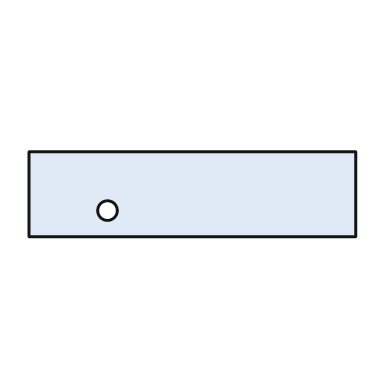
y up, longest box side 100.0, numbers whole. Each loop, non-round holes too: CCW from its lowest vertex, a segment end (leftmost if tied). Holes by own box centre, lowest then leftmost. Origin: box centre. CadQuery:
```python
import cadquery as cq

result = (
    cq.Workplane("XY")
    .moveTo(-50.0, -13.0)
    .lineTo(50.0, -13.0)
    .lineTo(50.0, 13.0)
    .lineTo(-50.0, 13.0)
    .close()
    .moveTo(-26.0, -5.0)
    .circle(3.0)
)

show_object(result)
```